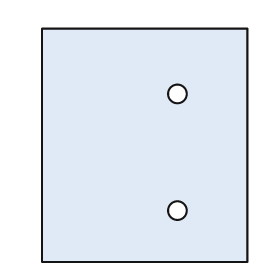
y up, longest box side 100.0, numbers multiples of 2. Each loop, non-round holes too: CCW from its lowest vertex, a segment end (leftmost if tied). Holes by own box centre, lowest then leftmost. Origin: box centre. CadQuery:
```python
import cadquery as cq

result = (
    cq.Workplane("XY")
    .moveTo(-44.0, -50.0)
    .lineTo(44.0, -50.0)
    .lineTo(44.0, 50.0)
    .lineTo(-44.0, 50.0)
    .close()
    .moveTo(14.0, -28.0)
    .circle(4.0)
    .moveTo(14.0, 22.0)
    .circle(4.0)
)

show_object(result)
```